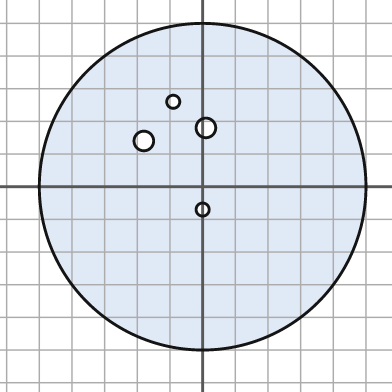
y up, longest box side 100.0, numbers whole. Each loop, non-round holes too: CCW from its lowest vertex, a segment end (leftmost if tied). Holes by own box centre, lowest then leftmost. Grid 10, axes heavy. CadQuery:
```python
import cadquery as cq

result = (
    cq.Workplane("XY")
    .moveTo(0.0, 0.0)
    .circle(50.0)
    .moveTo(0.0, -7.0)
    .circle(2.0)
    .moveTo(-18.0, 14.0)
    .circle(3.0)
    .moveTo(1.0, 18.0)
    .circle(3.0)
    .moveTo(-9.0, 26.0)
    .circle(2.0)
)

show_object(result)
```